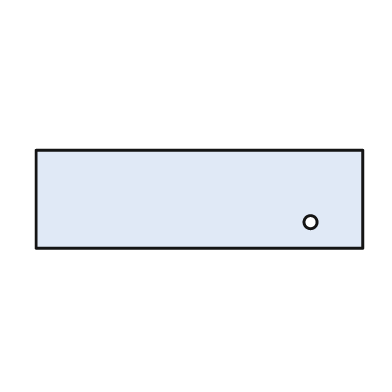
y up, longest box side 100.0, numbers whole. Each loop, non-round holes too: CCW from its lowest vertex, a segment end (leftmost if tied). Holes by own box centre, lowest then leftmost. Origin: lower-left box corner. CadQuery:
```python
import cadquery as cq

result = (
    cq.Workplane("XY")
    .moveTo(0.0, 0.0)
    .lineTo(100.0, 0.0)
    .lineTo(100.0, 30.0)
    .lineTo(0.0, 30.0)
    .close()
    .moveTo(84.0, 8.0)
    .circle(2.0)
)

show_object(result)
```